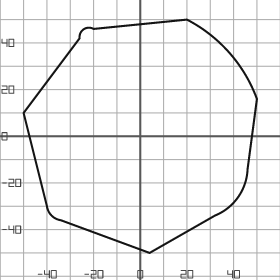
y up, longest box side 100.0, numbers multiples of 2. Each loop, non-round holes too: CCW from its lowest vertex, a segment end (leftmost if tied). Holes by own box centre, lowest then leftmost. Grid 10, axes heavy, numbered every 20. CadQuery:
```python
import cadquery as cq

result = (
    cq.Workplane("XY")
    .moveTo(4.0, -50.0)
    .lineTo(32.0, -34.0)
    .threePointArc((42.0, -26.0), (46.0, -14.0))
    .lineTo(50.0, 16.0)
    .threePointArc((38.0, 36.0), (20.0, 50.0))
    .lineTo(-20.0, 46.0)
    .threePointArc((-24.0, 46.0), (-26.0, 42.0))
    .lineTo(-50.0, 10.0)
    .lineTo(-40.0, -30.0)
    .threePointArc((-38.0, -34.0), (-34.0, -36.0))
    .close()
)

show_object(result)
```